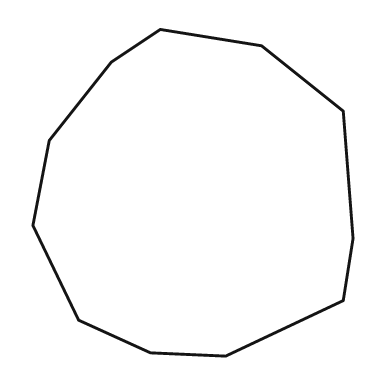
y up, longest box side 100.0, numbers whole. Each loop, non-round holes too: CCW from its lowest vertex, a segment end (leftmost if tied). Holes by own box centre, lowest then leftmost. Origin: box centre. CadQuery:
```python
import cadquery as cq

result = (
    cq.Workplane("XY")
    .moveTo(10.0, -50.0)
    .lineTo(46.0, -33.0)
    .lineTo(49.0, -14.0)
    .lineTo(46.0, 25.0)
    .lineTo(21.0, 45.0)
    .lineTo(-10.0, 50.0)
    .lineTo(-25.0, 40.0)
    .lineTo(-44.0, 16.0)
    .lineTo(-49.0, -10.0)
    .lineTo(-35.0, -39.0)
    .lineTo(-13.0, -49.0)
    .close()
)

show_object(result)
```